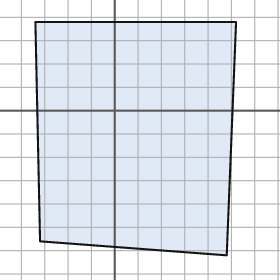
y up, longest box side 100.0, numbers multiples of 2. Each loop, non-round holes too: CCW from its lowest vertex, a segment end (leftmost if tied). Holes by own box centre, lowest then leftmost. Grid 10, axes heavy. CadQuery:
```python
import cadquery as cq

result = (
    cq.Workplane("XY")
    .moveTo(48.0, -62.0)
    .lineTo(52.0, 38.0)
    .lineTo(-34.0, 38.0)
    .lineTo(-32.0, -56.0)
    .close()
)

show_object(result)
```